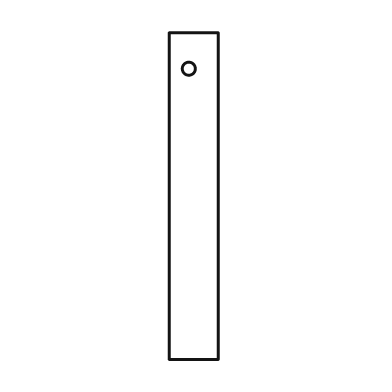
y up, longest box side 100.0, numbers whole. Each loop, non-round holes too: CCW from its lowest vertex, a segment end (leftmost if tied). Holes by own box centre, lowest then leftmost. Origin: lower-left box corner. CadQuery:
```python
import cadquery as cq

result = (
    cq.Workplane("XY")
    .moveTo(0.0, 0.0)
    .lineTo(15.0, 0.0)
    .lineTo(15.0, 100.0)
    .lineTo(0.0, 100.0)
    .close()
    .moveTo(6.0, 89.0)
    .circle(2.0)
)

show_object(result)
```